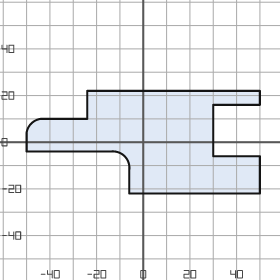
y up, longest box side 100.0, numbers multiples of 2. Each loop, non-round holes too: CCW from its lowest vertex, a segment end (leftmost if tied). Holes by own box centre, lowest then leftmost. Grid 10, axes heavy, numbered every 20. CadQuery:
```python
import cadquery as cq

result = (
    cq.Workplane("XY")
    .moveTo(-6.0, -22.0)
    .lineTo(50.0, -22.0)
    .lineTo(50.0, -6.0)
    .lineTo(30.0, -6.0)
    .lineTo(30.0, 16.0)
    .lineTo(50.0, 16.0)
    .lineTo(50.0, 22.0)
    .lineTo(-24.0, 22.0)
    .lineTo(-24.0, 10.0)
    .lineTo(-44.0, 10.0)
    .threePointArc((-48.0, 8.0), (-50.0, 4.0))
    .lineTo(-50.0, -4.0)
    .lineTo(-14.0, -4.0)
    .threePointArc((-8.0, -6.0), (-6.0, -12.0))
    .close()
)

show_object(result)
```